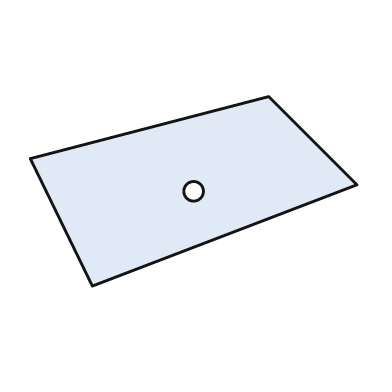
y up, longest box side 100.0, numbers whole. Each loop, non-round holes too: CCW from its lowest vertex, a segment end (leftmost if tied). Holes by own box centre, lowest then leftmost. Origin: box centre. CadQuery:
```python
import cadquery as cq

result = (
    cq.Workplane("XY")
    .moveTo(-31.0, -29.0)
    .lineTo(50.0, 2.0)
    .lineTo(23.0, 29.0)
    .lineTo(-50.0, 10.0)
    .close()
    .moveTo(0.0, 0.0)
    .circle(3.0)
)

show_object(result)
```